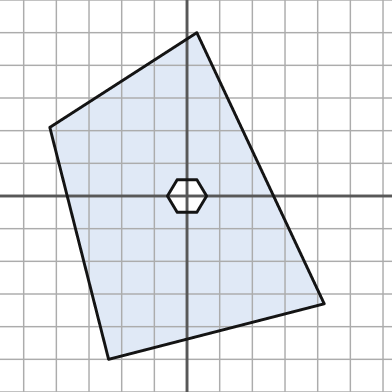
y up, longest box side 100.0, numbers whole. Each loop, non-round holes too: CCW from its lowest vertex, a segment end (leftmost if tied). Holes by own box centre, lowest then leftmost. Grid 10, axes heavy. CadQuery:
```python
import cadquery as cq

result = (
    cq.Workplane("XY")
    .moveTo(-24.0, -50.0)
    .lineTo(42.0, -33.0)
    .lineTo(3.0, 50.0)
    .lineTo(-42.0, 21.0)
    .close()
    .moveTo(-3.0, -5.0)
    .lineTo(3.0, -5.0)
    .lineTo(6.0, 0.0)
    .lineTo(3.0, 5.0)
    .lineTo(-3.0, 5.0)
    .lineTo(-6.0, 0.0)
    .close()
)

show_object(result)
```